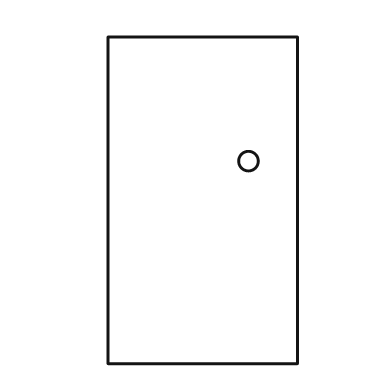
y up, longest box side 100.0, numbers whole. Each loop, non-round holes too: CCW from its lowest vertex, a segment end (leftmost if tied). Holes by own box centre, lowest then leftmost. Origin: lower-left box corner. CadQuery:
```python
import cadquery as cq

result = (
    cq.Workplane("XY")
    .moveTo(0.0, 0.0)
    .lineTo(58.0, 0.0)
    .lineTo(58.0, 100.0)
    .lineTo(0.0, 100.0)
    .close()
    .moveTo(43.0, 62.0)
    .circle(3.0)
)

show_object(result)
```